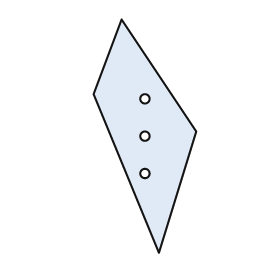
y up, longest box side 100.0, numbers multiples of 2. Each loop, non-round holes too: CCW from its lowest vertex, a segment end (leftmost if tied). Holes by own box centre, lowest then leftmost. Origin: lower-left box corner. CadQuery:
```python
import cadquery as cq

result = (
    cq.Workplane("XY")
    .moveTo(28.0, 0.0)
    .lineTo(44.0, 52.0)
    .lineTo(12.0, 100.0)
    .lineTo(0.0, 68.0)
    .close()
    .moveTo(22.0, 34.0)
    .circle(2.0)
    .moveTo(22.0, 50.0)
    .circle(2.0)
    .moveTo(22.0, 66.0)
    .circle(2.0)
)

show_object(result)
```